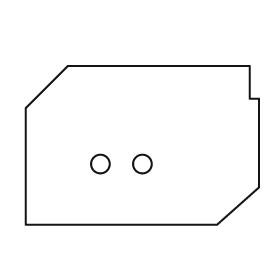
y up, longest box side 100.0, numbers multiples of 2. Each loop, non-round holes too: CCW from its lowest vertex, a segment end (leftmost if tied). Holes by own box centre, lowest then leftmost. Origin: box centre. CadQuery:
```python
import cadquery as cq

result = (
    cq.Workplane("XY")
    .moveTo(-50.0, -34.0)
    .lineTo(32.0, -34.0)
    .lineTo(50.0, -18.0)
    .lineTo(50.0, 20.0)
    .lineTo(46.0, 20.0)
    .lineTo(46.0, 34.0)
    .lineTo(-32.0, 34.0)
    .lineTo(-50.0, 16.0)
    .close()
    .moveTo(-18.0, -8.0)
    .circle(4.0)
    .moveTo(0.0, -8.0)
    .circle(4.0)
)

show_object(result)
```